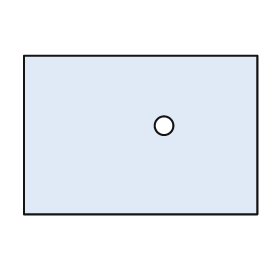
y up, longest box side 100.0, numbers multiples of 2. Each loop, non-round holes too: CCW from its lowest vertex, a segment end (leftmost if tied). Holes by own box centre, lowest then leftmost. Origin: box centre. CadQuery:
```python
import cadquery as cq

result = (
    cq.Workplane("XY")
    .moveTo(-50.0, -34.0)
    .lineTo(50.0, -34.0)
    .lineTo(50.0, 34.0)
    .lineTo(-50.0, 34.0)
    .close()
    .moveTo(10.0, 4.0)
    .circle(4.0)
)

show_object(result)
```